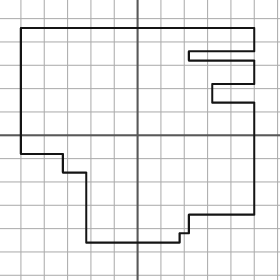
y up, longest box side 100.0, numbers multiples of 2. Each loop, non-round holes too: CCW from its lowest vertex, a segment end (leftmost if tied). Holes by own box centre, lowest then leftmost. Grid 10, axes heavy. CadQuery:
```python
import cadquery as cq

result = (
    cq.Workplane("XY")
    .moveTo(-22.0, -46.0)
    .lineTo(18.0, -46.0)
    .lineTo(18.0, -42.0)
    .lineTo(22.0, -42.0)
    .lineTo(22.0, -34.0)
    .lineTo(50.0, -34.0)
    .lineTo(50.0, 14.0)
    .lineTo(32.0, 14.0)
    .lineTo(32.0, 22.0)
    .lineTo(50.0, 22.0)
    .lineTo(50.0, 32.0)
    .lineTo(22.0, 32.0)
    .lineTo(22.0, 36.0)
    .lineTo(50.0, 36.0)
    .lineTo(50.0, 46.0)
    .lineTo(-50.0, 46.0)
    .lineTo(-50.0, -8.0)
    .lineTo(-32.0, -8.0)
    .lineTo(-32.0, -16.0)
    .lineTo(-22.0, -16.0)
    .close()
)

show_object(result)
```